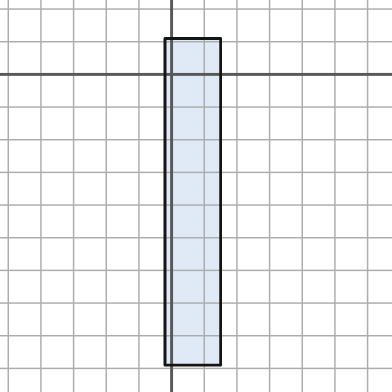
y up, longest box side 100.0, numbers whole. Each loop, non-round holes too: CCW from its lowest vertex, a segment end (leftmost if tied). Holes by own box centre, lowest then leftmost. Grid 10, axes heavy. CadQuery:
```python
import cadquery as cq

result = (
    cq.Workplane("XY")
    .moveTo(-2.0, -89.0)
    .lineTo(15.0, -89.0)
    .lineTo(15.0, 11.0)
    .lineTo(-2.0, 11.0)
    .close()
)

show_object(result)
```